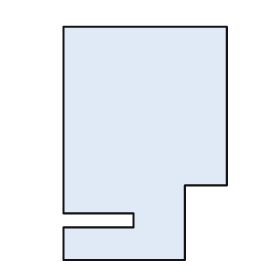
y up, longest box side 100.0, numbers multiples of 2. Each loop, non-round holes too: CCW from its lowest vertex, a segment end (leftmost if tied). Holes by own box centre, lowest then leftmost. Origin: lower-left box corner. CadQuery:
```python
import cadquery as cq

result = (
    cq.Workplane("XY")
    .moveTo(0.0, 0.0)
    .lineTo(52.0, 0.0)
    .lineTo(52.0, 32.0)
    .lineTo(70.0, 32.0)
    .lineTo(70.0, 100.0)
    .lineTo(0.0, 100.0)
    .lineTo(0.0, 20.0)
    .lineTo(30.0, 20.0)
    .lineTo(30.0, 14.0)
    .lineTo(0.0, 14.0)
    .close()
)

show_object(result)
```